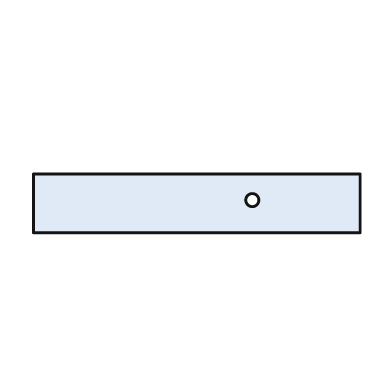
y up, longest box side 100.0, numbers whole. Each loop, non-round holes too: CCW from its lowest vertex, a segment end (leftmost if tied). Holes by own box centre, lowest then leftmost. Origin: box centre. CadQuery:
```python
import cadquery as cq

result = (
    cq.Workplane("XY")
    .moveTo(-50.0, -9.0)
    .lineTo(50.0, -9.0)
    .lineTo(50.0, 9.0)
    .lineTo(-50.0, 9.0)
    .close()
    .moveTo(17.0, 1.0)
    .circle(2.0)
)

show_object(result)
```